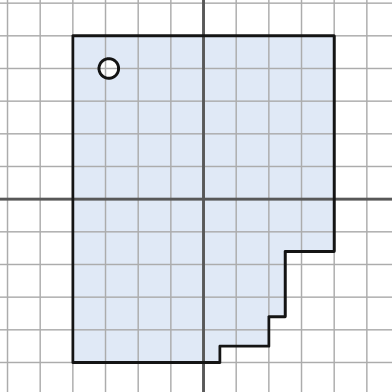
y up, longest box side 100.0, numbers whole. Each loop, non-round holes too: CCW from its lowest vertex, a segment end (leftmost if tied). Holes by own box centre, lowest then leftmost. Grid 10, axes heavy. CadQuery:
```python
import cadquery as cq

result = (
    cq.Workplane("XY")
    .moveTo(-40.0, -50.0)
    .lineTo(5.0, -50.0)
    .lineTo(5.0, -45.0)
    .lineTo(20.0, -45.0)
    .lineTo(20.0, -36.0)
    .lineTo(25.0, -36.0)
    .lineTo(25.0, -16.0)
    .lineTo(40.0, -16.0)
    .lineTo(40.0, 50.0)
    .lineTo(-40.0, 50.0)
    .close()
    .moveTo(-29.0, 40.0)
    .circle(3.0)
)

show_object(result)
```